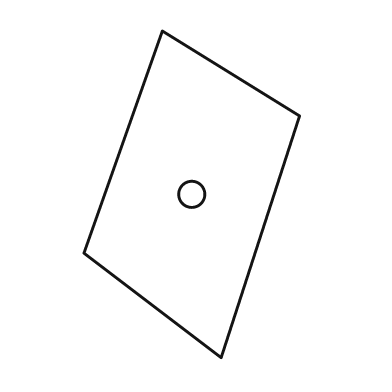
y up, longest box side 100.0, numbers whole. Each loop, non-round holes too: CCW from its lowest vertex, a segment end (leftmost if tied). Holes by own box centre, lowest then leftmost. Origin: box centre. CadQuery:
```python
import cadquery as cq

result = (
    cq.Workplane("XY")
    .moveTo(9.0, -50.0)
    .lineTo(33.0, 24.0)
    .lineTo(-9.0, 50.0)
    .lineTo(-33.0, -18.0)
    .close()
    .moveTo(0.0, 0.0)
    .circle(4.0)
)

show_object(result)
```